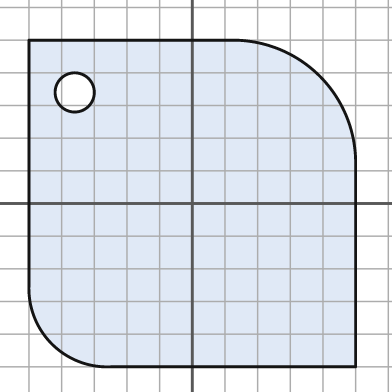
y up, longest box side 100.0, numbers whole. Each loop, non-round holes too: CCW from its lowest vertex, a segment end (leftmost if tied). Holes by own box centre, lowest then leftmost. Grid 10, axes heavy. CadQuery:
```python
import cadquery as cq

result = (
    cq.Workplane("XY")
    .moveTo(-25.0, -50.0)
    .lineTo(50.0, -50.0)
    .lineTo(50.0, 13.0)
    .threePointArc((39.0, 39.0), (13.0, 50.0))
    .lineTo(-50.0, 50.0)
    .lineTo(-50.0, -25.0)
    .threePointArc((-43.0, -43.0), (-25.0, -50.0))
    .close()
    .moveTo(-36.0, 34.0)
    .circle(6.0)
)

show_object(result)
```